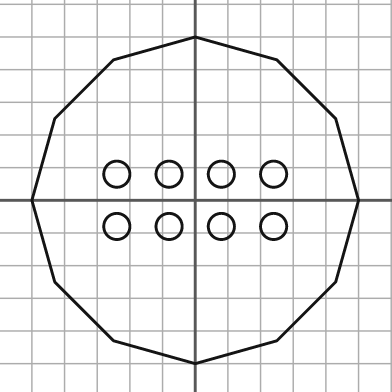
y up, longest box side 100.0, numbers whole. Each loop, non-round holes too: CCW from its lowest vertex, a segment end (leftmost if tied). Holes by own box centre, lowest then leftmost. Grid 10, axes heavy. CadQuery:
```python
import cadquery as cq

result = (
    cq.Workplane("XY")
    .moveTo(0.0, -50.0)
    .lineTo(25.0, -43.0)
    .lineTo(43.0, -25.0)
    .lineTo(50.0, 0.0)
    .lineTo(43.0, 25.0)
    .lineTo(25.0, 43.0)
    .lineTo(0.0, 50.0)
    .lineTo(-25.0, 43.0)
    .lineTo(-43.0, 25.0)
    .lineTo(-50.0, 0.0)
    .lineTo(-43.0, -25.0)
    .lineTo(-25.0, -43.0)
    .close()
    .moveTo(-24.0, -8.0)
    .circle(4.0)
    .moveTo(-8.0, -8.0)
    .circle(4.0)
    .moveTo(8.0, -8.0)
    .circle(4.0)
    .moveTo(24.0, -8.0)
    .circle(4.0)
    .moveTo(-24.0, 8.0)
    .circle(4.0)
    .moveTo(-8.0, 8.0)
    .circle(4.0)
    .moveTo(8.0, 8.0)
    .circle(4.0)
    .moveTo(24.0, 8.0)
    .circle(4.0)
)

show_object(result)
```